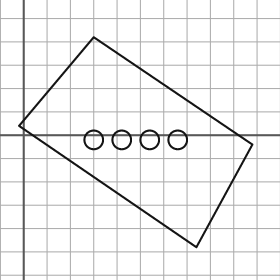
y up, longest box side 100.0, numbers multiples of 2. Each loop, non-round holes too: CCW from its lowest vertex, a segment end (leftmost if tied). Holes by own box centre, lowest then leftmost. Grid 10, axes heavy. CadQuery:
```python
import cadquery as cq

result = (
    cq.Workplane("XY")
    .moveTo(74.0, -48.0)
    .lineTo(98.0, -4.0)
    .lineTo(30.0, 42.0)
    .lineTo(-2.0, 4.0)
    .close()
    .moveTo(30.0, -2.0)
    .circle(4.0)
    .moveTo(42.0, -2.0)
    .circle(4.0)
    .moveTo(54.0, -2.0)
    .circle(4.0)
    .moveTo(66.0, -2.0)
    .circle(4.0)
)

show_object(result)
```